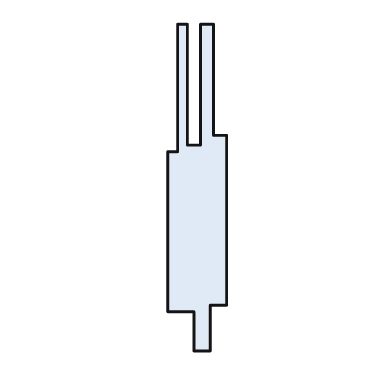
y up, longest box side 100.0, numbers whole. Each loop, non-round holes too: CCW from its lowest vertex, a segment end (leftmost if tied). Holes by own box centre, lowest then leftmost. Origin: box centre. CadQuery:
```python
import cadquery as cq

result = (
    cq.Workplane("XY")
    .moveTo(-1.0, -50.0)
    .lineTo(4.0, -50.0)
    .lineTo(4.0, -36.0)
    .lineTo(9.0, -36.0)
    .lineTo(9.0, 16.0)
    .lineTo(5.0, 16.0)
    .lineTo(5.0, 50.0)
    .lineTo(1.0, 50.0)
    .lineTo(1.0, 13.0)
    .lineTo(-3.0, 13.0)
    .lineTo(-3.0, 50.0)
    .lineTo(-6.0, 50.0)
    .lineTo(-6.0, 11.0)
    .lineTo(-9.0, 11.0)
    .lineTo(-9.0, -38.0)
    .lineTo(-1.0, -38.0)
    .close()
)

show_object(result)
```